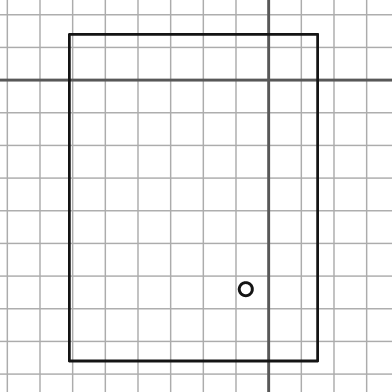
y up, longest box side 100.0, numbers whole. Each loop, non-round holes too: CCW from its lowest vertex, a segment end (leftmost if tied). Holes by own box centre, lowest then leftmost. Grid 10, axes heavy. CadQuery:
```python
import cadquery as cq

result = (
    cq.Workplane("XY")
    .moveTo(-61.0, -86.0)
    .lineTo(15.0, -86.0)
    .lineTo(15.0, 14.0)
    .lineTo(-61.0, 14.0)
    .close()
    .moveTo(-7.0, -64.0)
    .circle(2.0)
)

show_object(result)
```